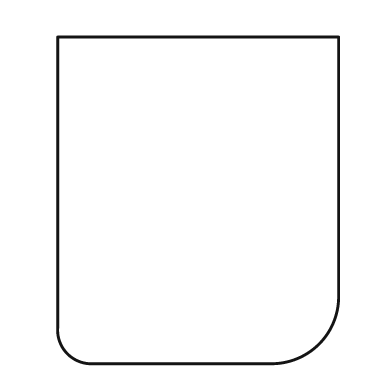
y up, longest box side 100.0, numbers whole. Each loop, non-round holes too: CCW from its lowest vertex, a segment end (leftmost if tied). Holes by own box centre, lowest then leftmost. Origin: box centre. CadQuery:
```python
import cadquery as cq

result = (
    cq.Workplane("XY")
    .moveTo(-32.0, -50.0)
    .lineTo(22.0, -50.0)
    .threePointArc((37.0, -44.0), (43.0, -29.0))
    .lineTo(43.0, 50.0)
    .lineTo(-43.0, 50.0)
    .lineTo(-43.0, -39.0)
    .threePointArc((-40.0, -47.0), (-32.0, -50.0))
    .close()
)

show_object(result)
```